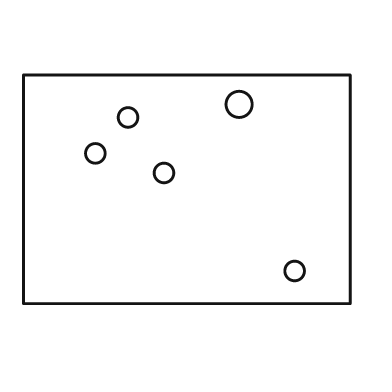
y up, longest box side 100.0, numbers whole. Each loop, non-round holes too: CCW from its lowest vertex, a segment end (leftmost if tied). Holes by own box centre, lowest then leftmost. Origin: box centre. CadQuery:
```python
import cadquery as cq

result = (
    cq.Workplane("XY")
    .moveTo(-50.0, -35.0)
    .lineTo(50.0, -35.0)
    .lineTo(50.0, 35.0)
    .lineTo(-50.0, 35.0)
    .close()
    .moveTo(33.0, -25.0)
    .circle(3.0)
    .moveTo(-7.0, 5.0)
    .circle(3.0)
    .moveTo(-28.0, 11.0)
    .circle(3.0)
    .moveTo(-18.0, 22.0)
    .circle(3.0)
    .moveTo(16.0, 26.0)
    .circle(4.0)
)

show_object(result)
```